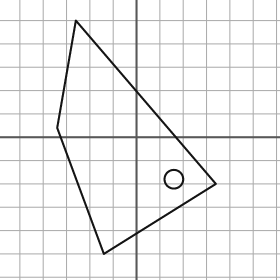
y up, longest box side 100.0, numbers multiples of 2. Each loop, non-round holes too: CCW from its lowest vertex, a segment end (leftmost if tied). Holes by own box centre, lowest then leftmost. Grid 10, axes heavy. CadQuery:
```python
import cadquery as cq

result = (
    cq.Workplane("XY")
    .moveTo(-14.0, -50.0)
    .lineTo(34.0, -20.0)
    .lineTo(-26.0, 50.0)
    .lineTo(-34.0, 4.0)
    .close()
    .moveTo(16.0, -18.0)
    .circle(4.0)
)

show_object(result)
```